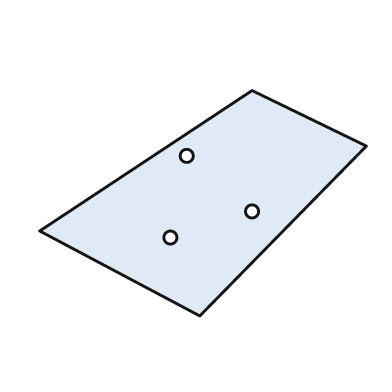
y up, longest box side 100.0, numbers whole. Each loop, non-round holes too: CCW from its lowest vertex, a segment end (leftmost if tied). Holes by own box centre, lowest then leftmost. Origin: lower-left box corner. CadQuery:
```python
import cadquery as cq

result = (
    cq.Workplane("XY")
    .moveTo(49.0, 0.0)
    .lineTo(100.0, 52.0)
    .lineTo(65.0, 69.0)
    .lineTo(0.0, 26.0)
    .close()
    .moveTo(40.0, 24.0)
    .circle(2.0)
    .moveTo(65.0, 32.0)
    .circle(2.0)
    .moveTo(45.0, 49.0)
    .circle(2.0)
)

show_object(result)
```